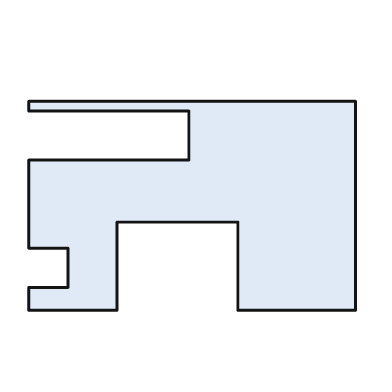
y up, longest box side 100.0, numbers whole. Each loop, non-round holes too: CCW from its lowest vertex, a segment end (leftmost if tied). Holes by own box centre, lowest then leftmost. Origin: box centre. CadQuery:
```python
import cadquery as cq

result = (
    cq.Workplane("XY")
    .moveTo(-50.0, -32.0)
    .lineTo(-23.0, -32.0)
    .lineTo(-23.0, -5.0)
    .lineTo(14.0, -5.0)
    .lineTo(14.0, -32.0)
    .lineTo(50.0, -32.0)
    .lineTo(50.0, 32.0)
    .lineTo(-50.0, 32.0)
    .lineTo(-50.0, 29.0)
    .lineTo(-1.0, 29.0)
    .lineTo(-1.0, 14.0)
    .lineTo(-50.0, 14.0)
    .lineTo(-50.0, -13.0)
    .lineTo(-38.0, -13.0)
    .lineTo(-38.0, -25.0)
    .lineTo(-50.0, -25.0)
    .close()
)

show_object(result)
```